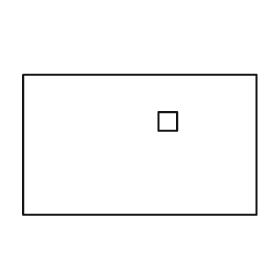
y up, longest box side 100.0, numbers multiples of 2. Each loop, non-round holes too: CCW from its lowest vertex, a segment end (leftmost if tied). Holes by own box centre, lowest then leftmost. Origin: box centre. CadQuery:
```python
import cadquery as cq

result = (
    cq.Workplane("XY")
    .moveTo(-50.0, -30.0)
    .lineTo(50.0, -30.0)
    .lineTo(50.0, 30.0)
    .lineTo(-50.0, 30.0)
    .close()
    .moveTo(8.0, 6.0)
    .lineTo(16.0, 6.0)
    .lineTo(16.0, 14.0)
    .lineTo(8.0, 14.0)
    .close()
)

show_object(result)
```